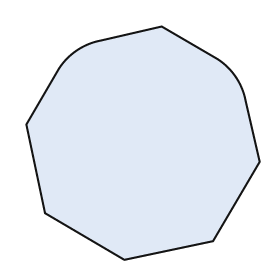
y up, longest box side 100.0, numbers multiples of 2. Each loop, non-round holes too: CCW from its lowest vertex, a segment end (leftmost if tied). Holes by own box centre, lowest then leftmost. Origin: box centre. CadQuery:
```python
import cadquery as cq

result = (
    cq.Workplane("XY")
    .moveTo(-8.0, -50.0)
    .lineTo(30.0, -42.0)
    .lineTo(50.0, -8.0)
    .lineTo(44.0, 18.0)
    .threePointArc((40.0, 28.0), (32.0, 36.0))
    .lineTo(8.0, 50.0)
    .lineTo(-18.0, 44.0)
    .threePointArc((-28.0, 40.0), (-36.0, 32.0))
    .lineTo(-50.0, 8.0)
    .lineTo(-42.0, -30.0)
    .close()
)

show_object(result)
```